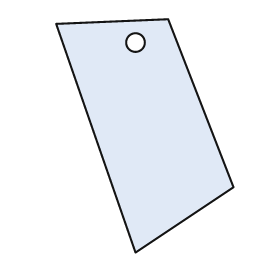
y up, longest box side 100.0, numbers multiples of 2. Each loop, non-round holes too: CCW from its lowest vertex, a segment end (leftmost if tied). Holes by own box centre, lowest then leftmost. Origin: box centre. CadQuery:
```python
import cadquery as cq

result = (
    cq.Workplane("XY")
    .moveTo(-4.0, -50.0)
    .lineTo(38.0, -22.0)
    .lineTo(10.0, 50.0)
    .lineTo(-38.0, 48.0)
    .close()
    .moveTo(-4.0, 40.0)
    .circle(4.0)
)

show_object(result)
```